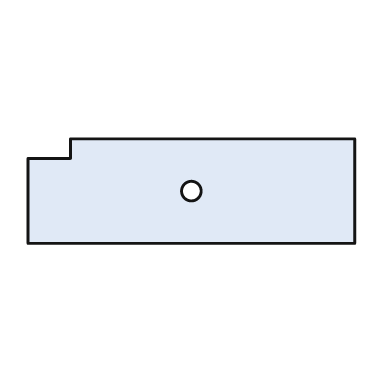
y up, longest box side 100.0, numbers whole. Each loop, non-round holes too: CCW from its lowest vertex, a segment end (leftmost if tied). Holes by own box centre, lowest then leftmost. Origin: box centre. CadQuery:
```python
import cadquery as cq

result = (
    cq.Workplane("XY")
    .moveTo(-50.0, -16.0)
    .lineTo(50.0, -16.0)
    .lineTo(50.0, 16.0)
    .lineTo(-37.0, 16.0)
    .lineTo(-37.0, 10.0)
    .lineTo(-50.0, 10.0)
    .close()
    .moveTo(0.0, 0.0)
    .circle(3.0)
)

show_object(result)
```